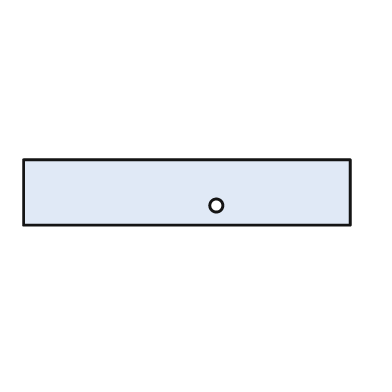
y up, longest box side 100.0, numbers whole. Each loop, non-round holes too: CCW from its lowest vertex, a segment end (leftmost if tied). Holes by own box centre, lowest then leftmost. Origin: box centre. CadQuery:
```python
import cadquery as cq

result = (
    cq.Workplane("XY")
    .moveTo(-50.0, -10.0)
    .lineTo(50.0, -10.0)
    .lineTo(50.0, 10.0)
    .lineTo(-50.0, 10.0)
    .close()
    .moveTo(9.0, -4.0)
    .circle(2.0)
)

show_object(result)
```